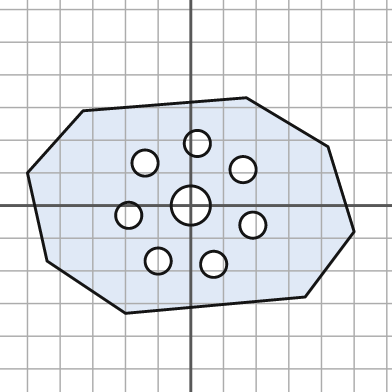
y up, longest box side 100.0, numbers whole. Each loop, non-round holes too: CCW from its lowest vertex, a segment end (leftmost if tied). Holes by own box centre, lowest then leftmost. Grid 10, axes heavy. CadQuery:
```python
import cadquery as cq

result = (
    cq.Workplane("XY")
    .moveTo(-20.0, -33.0)
    .lineTo(35.0, -28.0)
    .lineTo(50.0, -8.0)
    .lineTo(42.0, 18.0)
    .lineTo(17.0, 33.0)
    .lineTo(-33.0, 29.0)
    .lineTo(-50.0, 10.0)
    .lineTo(-44.0, -17.0)
    .close()
    .moveTo(7.0, -18.0)
    .circle(4.0)
    .moveTo(-10.0, -17.0)
    .circle(4.0)
    .moveTo(19.0, -6.0)
    .circle(4.0)
    .moveTo(-19.0, -3.0)
    .circle(4.0)
    .moveTo(0.0, 0.0)
    .circle(6.0)
    .moveTo(16.0, 11.0)
    .circle(4.0)
    .moveTo(-14.0, 13.0)
    .circle(4.0)
    .moveTo(2.0, 19.0)
    .circle(4.0)
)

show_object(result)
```